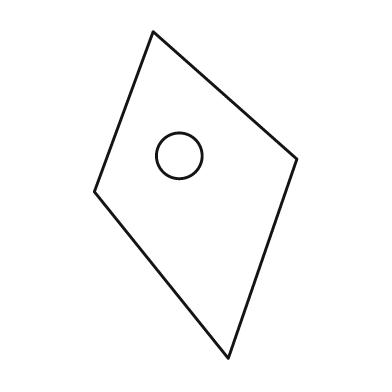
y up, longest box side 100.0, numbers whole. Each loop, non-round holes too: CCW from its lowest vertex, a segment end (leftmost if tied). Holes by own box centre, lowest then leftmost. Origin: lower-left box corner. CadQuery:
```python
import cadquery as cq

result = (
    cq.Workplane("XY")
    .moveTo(41.0, 0.0)
    .lineTo(62.0, 61.0)
    .lineTo(18.0, 100.0)
    .lineTo(0.0, 51.0)
    .close()
    .moveTo(26.0, 62.0)
    .circle(7.0)
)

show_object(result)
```